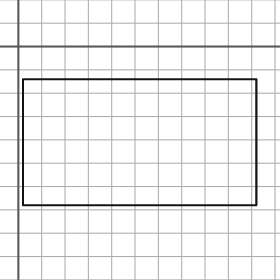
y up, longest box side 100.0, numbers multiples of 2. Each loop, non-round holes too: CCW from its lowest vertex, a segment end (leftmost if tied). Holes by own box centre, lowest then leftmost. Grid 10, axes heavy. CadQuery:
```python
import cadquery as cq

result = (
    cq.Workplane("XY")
    .moveTo(2.0, -68.0)
    .lineTo(102.0, -68.0)
    .lineTo(102.0, -14.0)
    .lineTo(2.0, -14.0)
    .close()
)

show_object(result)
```